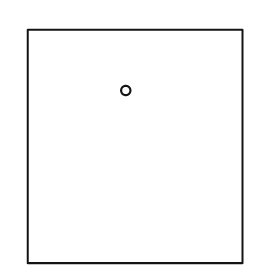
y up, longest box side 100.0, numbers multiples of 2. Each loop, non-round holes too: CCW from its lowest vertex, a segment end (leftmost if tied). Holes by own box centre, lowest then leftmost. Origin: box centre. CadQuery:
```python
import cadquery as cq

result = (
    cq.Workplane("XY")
    .moveTo(-46.0, -50.0)
    .lineTo(46.0, -50.0)
    .lineTo(46.0, 50.0)
    .lineTo(-46.0, 50.0)
    .close()
    .moveTo(-4.0, 24.0)
    .circle(2.0)
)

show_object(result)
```